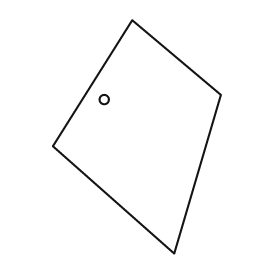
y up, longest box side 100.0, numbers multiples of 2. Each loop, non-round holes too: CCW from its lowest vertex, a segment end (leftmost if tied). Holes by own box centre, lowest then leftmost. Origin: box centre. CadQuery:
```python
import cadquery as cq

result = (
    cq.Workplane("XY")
    .moveTo(16.0, -50.0)
    .lineTo(36.0, 18.0)
    .lineTo(-2.0, 50.0)
    .lineTo(-36.0, -4.0)
    .close()
    .moveTo(-14.0, 16.0)
    .circle(2.0)
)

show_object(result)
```